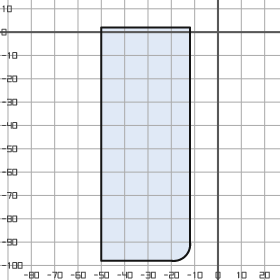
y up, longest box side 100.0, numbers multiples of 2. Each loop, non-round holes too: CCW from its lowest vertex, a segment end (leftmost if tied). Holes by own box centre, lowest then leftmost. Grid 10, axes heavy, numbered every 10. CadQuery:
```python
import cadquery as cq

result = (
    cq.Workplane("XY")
    .moveTo(-50.0, -98.0)
    .lineTo(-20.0, -98.0)
    .threePointArc((-14.0, -96.0), (-12.0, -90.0))
    .lineTo(-12.0, 2.0)
    .lineTo(-50.0, 2.0)
    .close()
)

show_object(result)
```